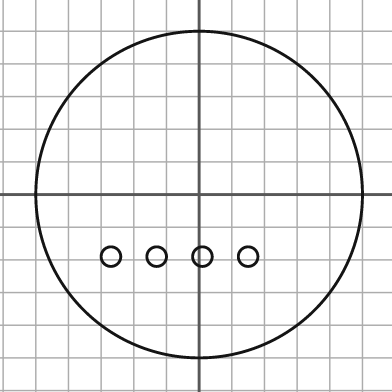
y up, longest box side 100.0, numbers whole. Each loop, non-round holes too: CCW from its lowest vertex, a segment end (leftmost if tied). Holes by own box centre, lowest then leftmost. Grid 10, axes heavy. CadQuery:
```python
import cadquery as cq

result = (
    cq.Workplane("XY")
    .moveTo(0.0, 0.0)
    .circle(50.0)
    .moveTo(-27.0, -19.0)
    .circle(3.0)
    .moveTo(-13.0, -19.0)
    .circle(3.0)
    .moveTo(1.0, -19.0)
    .circle(3.0)
    .moveTo(15.0, -19.0)
    .circle(3.0)
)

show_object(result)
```